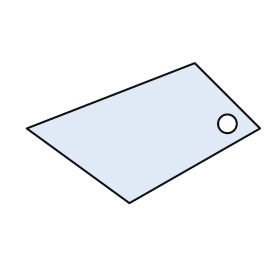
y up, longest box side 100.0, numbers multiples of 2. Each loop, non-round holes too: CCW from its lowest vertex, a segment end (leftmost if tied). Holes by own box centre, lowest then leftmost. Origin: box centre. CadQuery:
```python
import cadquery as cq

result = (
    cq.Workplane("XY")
    .moveTo(-6.0, -30.0)
    .lineTo(50.0, 2.0)
    .lineTo(22.0, 30.0)
    .lineTo(-50.0, 2.0)
    .close()
    .moveTo(36.0, 4.0)
    .circle(4.0)
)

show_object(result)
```